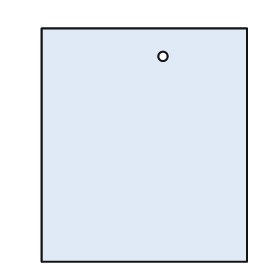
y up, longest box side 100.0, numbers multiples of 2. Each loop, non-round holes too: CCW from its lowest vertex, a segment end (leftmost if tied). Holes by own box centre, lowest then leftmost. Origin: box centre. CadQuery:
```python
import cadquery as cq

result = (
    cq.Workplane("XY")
    .moveTo(-44.0, -50.0)
    .lineTo(44.0, -50.0)
    .lineTo(44.0, 50.0)
    .lineTo(-44.0, 50.0)
    .close()
    .moveTo(8.0, 38.0)
    .circle(2.0)
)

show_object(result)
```